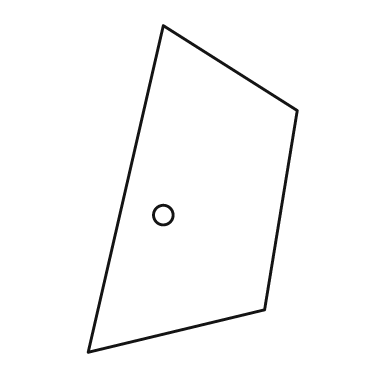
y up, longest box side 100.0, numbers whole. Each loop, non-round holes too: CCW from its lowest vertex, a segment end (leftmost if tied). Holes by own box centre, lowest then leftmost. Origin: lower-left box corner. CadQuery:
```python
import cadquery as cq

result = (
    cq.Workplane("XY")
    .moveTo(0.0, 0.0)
    .lineTo(54.0, 13.0)
    .lineTo(64.0, 74.0)
    .lineTo(23.0, 100.0)
    .close()
    .moveTo(23.0, 42.0)
    .circle(3.0)
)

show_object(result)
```